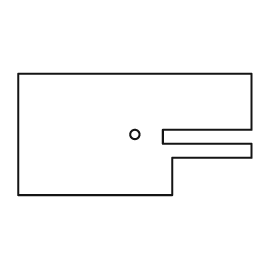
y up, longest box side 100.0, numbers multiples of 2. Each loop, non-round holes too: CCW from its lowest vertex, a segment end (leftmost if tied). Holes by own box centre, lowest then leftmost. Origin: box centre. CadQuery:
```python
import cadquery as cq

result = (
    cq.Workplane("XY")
    .moveTo(-50.0, -26.0)
    .lineTo(16.0, -26.0)
    .lineTo(16.0, -10.0)
    .lineTo(50.0, -10.0)
    .lineTo(50.0, -4.0)
    .lineTo(12.0, -4.0)
    .lineTo(12.0, 2.0)
    .lineTo(50.0, 2.0)
    .lineTo(50.0, 26.0)
    .lineTo(-50.0, 26.0)
    .close()
    .moveTo(0.0, 0.0)
    .circle(2.0)
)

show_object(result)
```